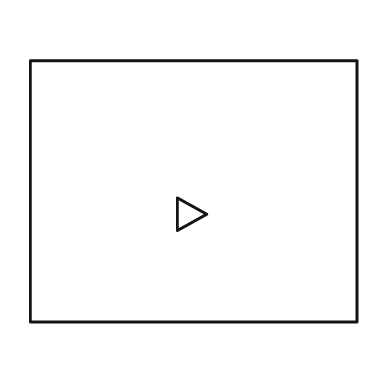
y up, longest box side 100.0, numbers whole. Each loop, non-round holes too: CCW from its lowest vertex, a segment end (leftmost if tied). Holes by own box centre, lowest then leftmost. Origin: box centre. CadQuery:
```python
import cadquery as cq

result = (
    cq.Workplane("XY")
    .moveTo(-50.0, -40.0)
    .lineTo(50.0, -40.0)
    .lineTo(50.0, 40.0)
    .lineTo(-50.0, 40.0)
    .close()
    .moveTo(-5.0, -12.0)
    .lineTo(4.0, -7.0)
    .lineTo(-5.0, -2.0)
    .close()
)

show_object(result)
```